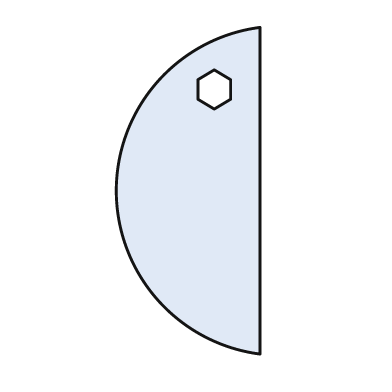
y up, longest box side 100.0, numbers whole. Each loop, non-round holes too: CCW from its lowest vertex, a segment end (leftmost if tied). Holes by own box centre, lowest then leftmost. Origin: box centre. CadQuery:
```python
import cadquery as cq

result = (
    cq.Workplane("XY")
    .moveTo(22.0, -50.0)
    .lineTo(22.0, 50.0)
    .threePointArc((-22.0, 0.0), (22.0, -50.0))
    .close()
    .moveTo(8.0, 25.0)
    .lineTo(13.0, 28.0)
    .lineTo(13.0, 34.0)
    .lineTo(8.0, 37.0)
    .lineTo(3.0, 34.0)
    .lineTo(3.0, 28.0)
    .close()
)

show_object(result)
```